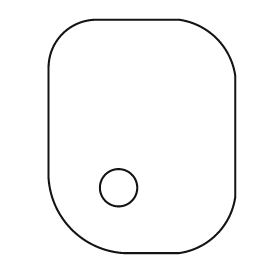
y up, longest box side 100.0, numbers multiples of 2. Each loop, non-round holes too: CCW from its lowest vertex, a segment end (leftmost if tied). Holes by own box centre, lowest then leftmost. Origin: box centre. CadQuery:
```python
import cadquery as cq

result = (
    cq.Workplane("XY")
    .moveTo(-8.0, -50.0)
    .lineTo(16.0, -50.0)
    .threePointArc((32.0, -42.0), (40.0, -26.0))
    .lineTo(40.0, 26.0)
    .threePointArc((32.0, 42.0), (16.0, 50.0))
    .lineTo(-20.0, 50.0)
    .threePointArc((-34.0, 44.0), (-40.0, 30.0))
    .lineTo(-40.0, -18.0)
    .threePointArc((-30.0, -40.0), (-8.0, -50.0))
    .close()
    .moveTo(-10.0, -22.0)
    .circle(8.0)
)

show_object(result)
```